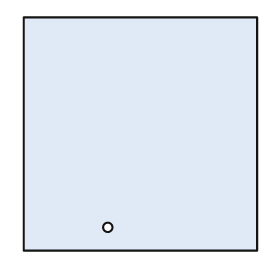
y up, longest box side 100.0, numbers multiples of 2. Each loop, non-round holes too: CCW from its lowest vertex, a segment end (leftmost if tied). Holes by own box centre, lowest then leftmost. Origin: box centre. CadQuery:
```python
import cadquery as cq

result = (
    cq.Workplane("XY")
    .moveTo(-50.0, -50.0)
    .lineTo(50.0, -50.0)
    .lineTo(50.0, 50.0)
    .lineTo(-50.0, 50.0)
    .close()
    .moveTo(-14.0, -40.0)
    .circle(2.0)
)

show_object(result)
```